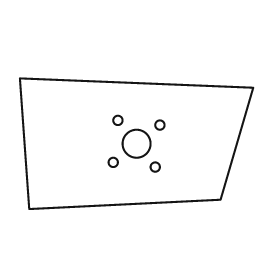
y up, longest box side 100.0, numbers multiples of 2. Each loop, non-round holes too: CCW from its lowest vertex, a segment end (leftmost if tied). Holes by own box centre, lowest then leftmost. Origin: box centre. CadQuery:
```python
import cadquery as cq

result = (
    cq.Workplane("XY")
    .moveTo(-46.0, -28.0)
    .lineTo(36.0, -24.0)
    .lineTo(50.0, 24.0)
    .lineTo(-50.0, 28.0)
    .close()
    .moveTo(8.0, -10.0)
    .circle(2.0)
    .moveTo(-10.0, -8.0)
    .circle(2.0)
    .moveTo(0.0, 0.0)
    .circle(6.0)
    .moveTo(10.0, 8.0)
    .circle(2.0)
    .moveTo(-8.0, 10.0)
    .circle(2.0)
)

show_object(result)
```